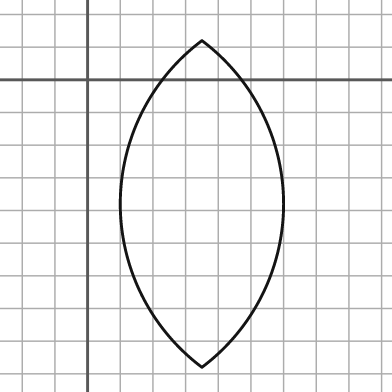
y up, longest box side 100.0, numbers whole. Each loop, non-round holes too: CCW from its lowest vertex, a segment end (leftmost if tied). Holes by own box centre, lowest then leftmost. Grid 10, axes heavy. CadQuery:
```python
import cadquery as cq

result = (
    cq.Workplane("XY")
    .moveTo(35.0, -88.0)
    .threePointArc((60.0, -38.0), (35.0, 12.0))
    .threePointArc((10.0, -38.0), (35.0, -88.0))
    .close()
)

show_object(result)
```